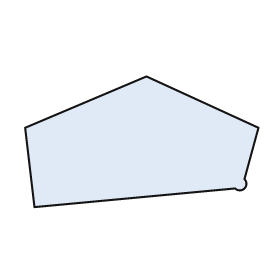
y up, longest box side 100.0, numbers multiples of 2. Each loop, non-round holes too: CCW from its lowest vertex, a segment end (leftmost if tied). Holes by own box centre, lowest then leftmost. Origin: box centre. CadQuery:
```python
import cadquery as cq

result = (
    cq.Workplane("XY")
    .moveTo(-46.0, -28.0)
    .lineTo(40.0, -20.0)
    .threePointArc((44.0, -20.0), (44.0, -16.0))
    .lineTo(50.0, 6.0)
    .lineTo(2.0, 28.0)
    .lineTo(-50.0, 6.0)
    .close()
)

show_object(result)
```